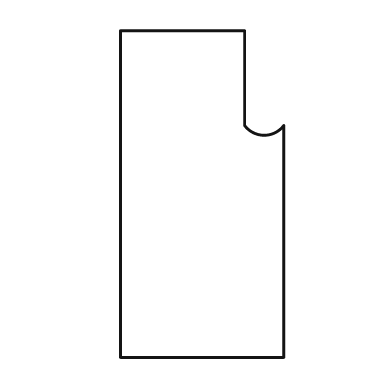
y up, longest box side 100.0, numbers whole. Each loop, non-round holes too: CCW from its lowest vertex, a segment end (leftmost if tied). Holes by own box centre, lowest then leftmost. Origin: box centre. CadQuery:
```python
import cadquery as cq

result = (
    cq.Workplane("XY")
    .moveTo(-25.0, -50.0)
    .lineTo(25.0, -50.0)
    .lineTo(25.0, 21.0)
    .threePointArc((19.0, 18.0), (13.0, 21.0))
    .lineTo(13.0, 50.0)
    .lineTo(-25.0, 50.0)
    .close()
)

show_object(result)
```